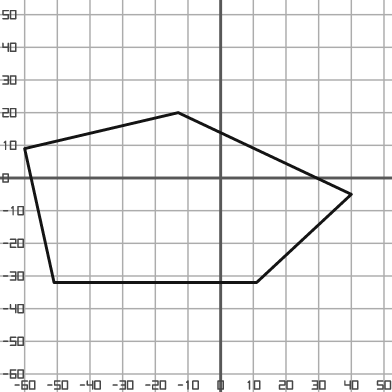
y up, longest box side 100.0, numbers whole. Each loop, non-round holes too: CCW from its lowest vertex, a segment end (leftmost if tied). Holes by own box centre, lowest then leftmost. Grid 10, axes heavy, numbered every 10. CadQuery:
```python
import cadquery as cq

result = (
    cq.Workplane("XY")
    .moveTo(-51.0, -32.0)
    .lineTo(11.0, -32.0)
    .lineTo(40.0, -5.0)
    .lineTo(-13.0, 20.0)
    .lineTo(-60.0, 9.0)
    .close()
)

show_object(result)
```